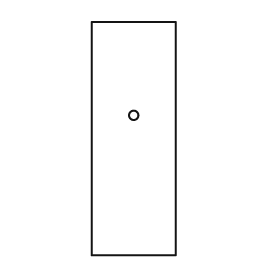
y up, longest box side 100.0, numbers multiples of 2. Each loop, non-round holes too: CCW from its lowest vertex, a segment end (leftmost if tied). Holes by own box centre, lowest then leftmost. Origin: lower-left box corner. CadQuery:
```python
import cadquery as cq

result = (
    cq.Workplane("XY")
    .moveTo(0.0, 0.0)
    .lineTo(36.0, 0.0)
    .lineTo(36.0, 100.0)
    .lineTo(0.0, 100.0)
    .close()
    .moveTo(18.0, 60.0)
    .circle(2.0)
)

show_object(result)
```